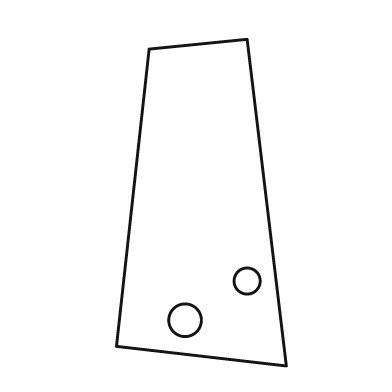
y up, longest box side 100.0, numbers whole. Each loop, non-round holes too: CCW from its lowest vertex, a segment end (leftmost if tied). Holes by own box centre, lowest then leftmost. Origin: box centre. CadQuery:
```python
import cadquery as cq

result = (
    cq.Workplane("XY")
    .moveTo(26.0, -50.0)
    .lineTo(14.0, 50.0)
    .lineTo(-16.0, 47.0)
    .lineTo(-26.0, -44.0)
    .close()
    .moveTo(-5.0, -36.0)
    .circle(5.0)
    .moveTo(14.0, -24.0)
    .circle(4.0)
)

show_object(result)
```